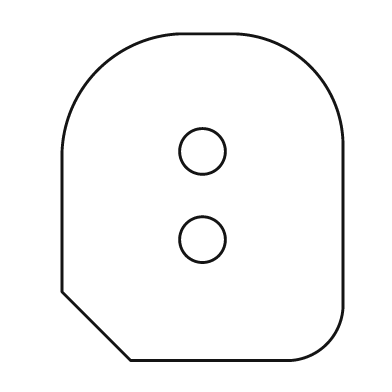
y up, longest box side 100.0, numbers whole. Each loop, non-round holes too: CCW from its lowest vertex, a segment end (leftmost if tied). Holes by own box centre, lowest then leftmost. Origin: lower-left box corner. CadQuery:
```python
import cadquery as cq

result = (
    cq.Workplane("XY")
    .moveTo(21.0, 0.0)
    .lineTo(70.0, 0.0)
    .threePointArc((81.0, 5.0), (86.0, 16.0))
    .lineTo(86.0, 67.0)
    .threePointArc((76.0, 90.0), (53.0, 100.0))
    .lineTo(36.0, 100.0)
    .threePointArc((11.0, 89.0), (0.0, 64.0))
    .lineTo(0.0, 21.0)
    .close()
    .moveTo(43.0, 37.0)
    .circle(7.0)
    .moveTo(43.0, 64.0)
    .circle(7.0)
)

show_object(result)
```